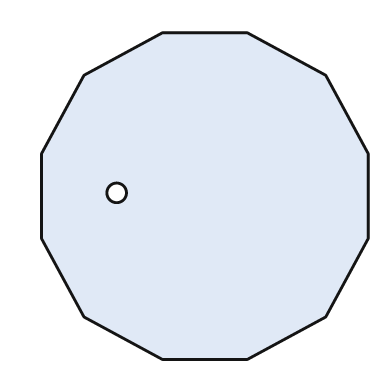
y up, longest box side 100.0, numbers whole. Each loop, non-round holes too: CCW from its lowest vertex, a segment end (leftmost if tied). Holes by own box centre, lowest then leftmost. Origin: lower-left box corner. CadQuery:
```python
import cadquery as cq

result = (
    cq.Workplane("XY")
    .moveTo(37.0, 0.0)
    .lineTo(63.0, 0.0)
    .lineTo(87.0, 13.0)
    .lineTo(100.0, 37.0)
    .lineTo(100.0, 63.0)
    .lineTo(87.0, 87.0)
    .lineTo(63.0, 100.0)
    .lineTo(37.0, 100.0)
    .lineTo(13.0, 87.0)
    .lineTo(0.0, 63.0)
    .lineTo(0.0, 37.0)
    .lineTo(13.0, 13.0)
    .close()
    .moveTo(23.0, 51.0)
    .circle(3.0)
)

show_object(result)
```